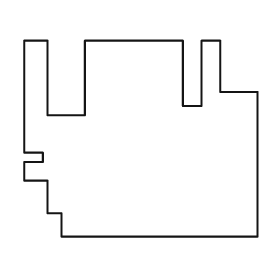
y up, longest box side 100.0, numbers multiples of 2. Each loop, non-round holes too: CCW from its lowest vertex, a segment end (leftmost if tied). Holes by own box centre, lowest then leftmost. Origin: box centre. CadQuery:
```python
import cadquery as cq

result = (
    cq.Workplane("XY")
    .moveTo(-34.0, -42.0)
    .lineTo(50.0, -42.0)
    .lineTo(50.0, 20.0)
    .lineTo(34.0, 20.0)
    .lineTo(34.0, 42.0)
    .lineTo(26.0, 42.0)
    .lineTo(26.0, 14.0)
    .lineTo(18.0, 14.0)
    .lineTo(18.0, 42.0)
    .lineTo(-24.0, 42.0)
    .lineTo(-24.0, 10.0)
    .lineTo(-40.0, 10.0)
    .lineTo(-40.0, 42.0)
    .lineTo(-50.0, 42.0)
    .lineTo(-50.0, -6.0)
    .lineTo(-42.0, -6.0)
    .lineTo(-42.0, -10.0)
    .lineTo(-50.0, -10.0)
    .lineTo(-50.0, -18.0)
    .lineTo(-40.0, -18.0)
    .lineTo(-40.0, -32.0)
    .lineTo(-34.0, -32.0)
    .close()
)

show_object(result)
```